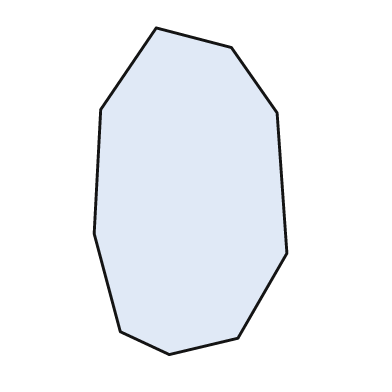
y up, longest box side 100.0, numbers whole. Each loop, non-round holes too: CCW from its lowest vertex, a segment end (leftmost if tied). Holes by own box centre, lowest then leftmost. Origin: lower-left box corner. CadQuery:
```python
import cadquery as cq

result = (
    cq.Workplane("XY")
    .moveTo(23.0, 0.0)
    .lineTo(44.0, 5.0)
    .lineTo(59.0, 31.0)
    .lineTo(56.0, 74.0)
    .lineTo(42.0, 94.0)
    .lineTo(19.0, 100.0)
    .lineTo(2.0, 75.0)
    .lineTo(0.0, 37.0)
    .lineTo(8.0, 7.0)
    .close()
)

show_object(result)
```